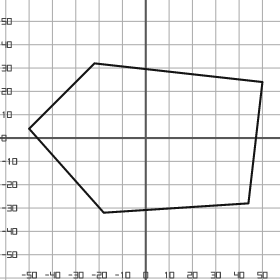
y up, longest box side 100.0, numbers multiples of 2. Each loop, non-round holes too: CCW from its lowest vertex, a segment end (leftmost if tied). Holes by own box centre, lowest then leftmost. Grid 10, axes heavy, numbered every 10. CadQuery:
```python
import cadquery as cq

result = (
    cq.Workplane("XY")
    .moveTo(-18.0, -32.0)
    .lineTo(44.0, -28.0)
    .lineTo(50.0, 24.0)
    .lineTo(-22.0, 32.0)
    .lineTo(-50.0, 4.0)
    .close()
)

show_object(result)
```